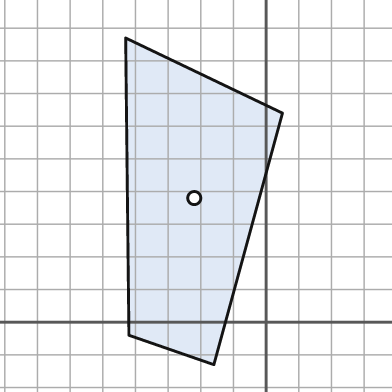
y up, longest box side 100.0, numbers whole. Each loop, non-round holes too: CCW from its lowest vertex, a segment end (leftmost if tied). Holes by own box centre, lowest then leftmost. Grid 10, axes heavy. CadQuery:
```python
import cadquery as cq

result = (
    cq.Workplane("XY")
    .moveTo(-16.0, -13.0)
    .lineTo(5.0, 64.0)
    .lineTo(-43.0, 87.0)
    .lineTo(-42.0, -4.0)
    .close()
    .moveTo(-22.0, 38.0)
    .circle(2.0)
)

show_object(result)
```